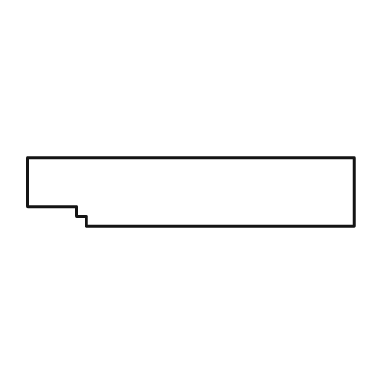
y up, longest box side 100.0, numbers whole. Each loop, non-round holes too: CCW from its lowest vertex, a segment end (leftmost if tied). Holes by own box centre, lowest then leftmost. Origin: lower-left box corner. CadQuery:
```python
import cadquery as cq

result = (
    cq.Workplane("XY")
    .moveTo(18.0, 0.0)
    .lineTo(100.0, 0.0)
    .lineTo(100.0, 21.0)
    .lineTo(0.0, 21.0)
    .lineTo(0.0, 6.0)
    .lineTo(15.0, 6.0)
    .lineTo(15.0, 3.0)
    .lineTo(18.0, 3.0)
    .close()
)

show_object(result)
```